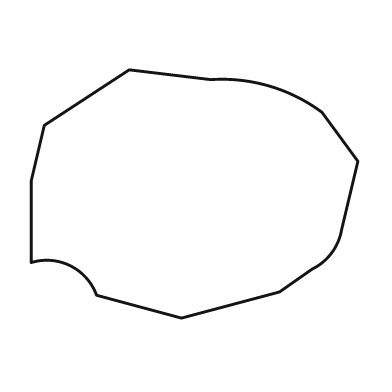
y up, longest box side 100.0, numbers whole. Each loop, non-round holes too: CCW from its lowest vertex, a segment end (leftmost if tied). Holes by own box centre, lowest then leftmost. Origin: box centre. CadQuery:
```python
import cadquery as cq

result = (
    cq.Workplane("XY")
    .moveTo(-4.0, -38.0)
    .lineTo(26.0, -30.0)
    .lineTo(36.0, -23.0)
    .threePointArc((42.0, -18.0), (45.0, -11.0))
    .lineTo(50.0, 10.0)
    .lineTo(39.0, 25.0)
    .threePointArc((23.0, 33.0), (5.0, 35.0))
    .lineTo(-20.0, 38.0)
    .lineTo(-46.0, 21.0)
    .lineTo(-50.0, 4.0)
    .lineTo(-50.0, -21.0)
    .threePointArc((-38.0, -22.0), (-30.0, -31.0))
    .close()
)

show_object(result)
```